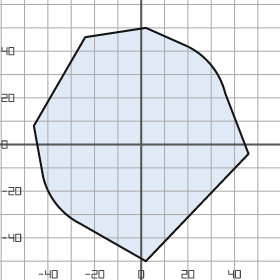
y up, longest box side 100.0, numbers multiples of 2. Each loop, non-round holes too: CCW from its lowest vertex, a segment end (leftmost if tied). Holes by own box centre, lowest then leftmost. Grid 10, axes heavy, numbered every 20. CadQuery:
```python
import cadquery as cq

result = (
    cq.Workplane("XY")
    .moveTo(2.0, -50.0)
    .lineTo(46.0, -4.0)
    .lineTo(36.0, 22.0)
    .threePointArc((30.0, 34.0), (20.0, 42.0))
    .lineTo(2.0, 50.0)
    .lineTo(-24.0, 46.0)
    .lineTo(-46.0, 8.0)
    .lineTo(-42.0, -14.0)
    .threePointArc((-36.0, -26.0), (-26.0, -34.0))
    .close()
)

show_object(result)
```